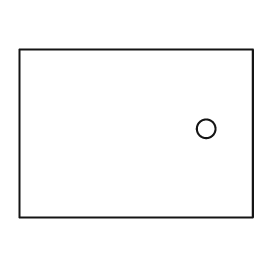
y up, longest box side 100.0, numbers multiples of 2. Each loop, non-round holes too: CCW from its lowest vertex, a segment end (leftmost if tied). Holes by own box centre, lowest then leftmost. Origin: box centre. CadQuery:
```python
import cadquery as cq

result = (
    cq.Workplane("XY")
    .moveTo(-50.0, -36.0)
    .lineTo(50.0, -36.0)
    .lineTo(50.0, 36.0)
    .lineTo(-50.0, 36.0)
    .close()
    .moveTo(30.0, 2.0)
    .circle(4.0)
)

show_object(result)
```